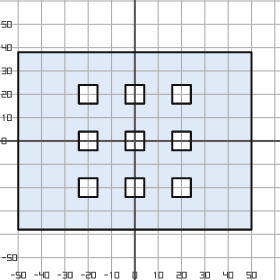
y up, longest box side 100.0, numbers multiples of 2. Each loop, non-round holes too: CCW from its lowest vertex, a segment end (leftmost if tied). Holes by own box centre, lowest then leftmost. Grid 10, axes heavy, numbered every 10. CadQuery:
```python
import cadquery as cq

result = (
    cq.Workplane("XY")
    .moveTo(-50.0, -38.0)
    .lineTo(50.0, -38.0)
    .lineTo(50.0, 38.0)
    .lineTo(-50.0, 38.0)
    .close()
    .moveTo(-24.0, -24.0)
    .lineTo(-16.0, -24.0)
    .lineTo(-16.0, -16.0)
    .lineTo(-24.0, -16.0)
    .close()
    .moveTo(-4.0, -24.0)
    .lineTo(4.0, -24.0)
    .lineTo(4.0, -16.0)
    .lineTo(-4.0, -16.0)
    .close()
    .moveTo(16.0, -24.0)
    .lineTo(24.0, -24.0)
    .lineTo(24.0, -16.0)
    .lineTo(16.0, -16.0)
    .close()
    .moveTo(-24.0, -4.0)
    .lineTo(-16.0, -4.0)
    .lineTo(-16.0, 4.0)
    .lineTo(-24.0, 4.0)
    .close()
    .moveTo(-4.0, -4.0)
    .lineTo(4.0, -4.0)
    .lineTo(4.0, 4.0)
    .lineTo(-4.0, 4.0)
    .close()
    .moveTo(16.0, -4.0)
    .lineTo(24.0, -4.0)
    .lineTo(24.0, 4.0)
    .lineTo(16.0, 4.0)
    .close()
    .moveTo(-24.0, 16.0)
    .lineTo(-16.0, 16.0)
    .lineTo(-16.0, 24.0)
    .lineTo(-24.0, 24.0)
    .close()
    .moveTo(-4.0, 16.0)
    .lineTo(4.0, 16.0)
    .lineTo(4.0, 24.0)
    .lineTo(-4.0, 24.0)
    .close()
    .moveTo(16.0, 16.0)
    .lineTo(24.0, 16.0)
    .lineTo(24.0, 24.0)
    .lineTo(16.0, 24.0)
    .close()
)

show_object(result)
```